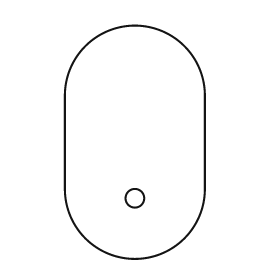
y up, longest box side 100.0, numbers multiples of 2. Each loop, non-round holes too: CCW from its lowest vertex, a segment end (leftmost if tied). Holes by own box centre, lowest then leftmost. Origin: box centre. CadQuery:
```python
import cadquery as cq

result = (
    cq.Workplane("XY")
    .moveTo(-30.0, -20.0)
    .threePointArc((0.0, -50.0), (30.0, -20.0))
    .lineTo(30.0, 20.0)
    .threePointArc((0.0, 50.0), (-30.0, 20.0))
    .close()
    .moveTo(0.0, -24.0)
    .circle(4.0)
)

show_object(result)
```